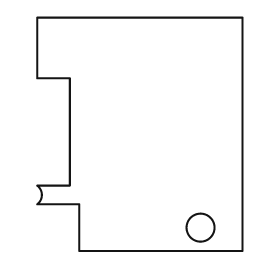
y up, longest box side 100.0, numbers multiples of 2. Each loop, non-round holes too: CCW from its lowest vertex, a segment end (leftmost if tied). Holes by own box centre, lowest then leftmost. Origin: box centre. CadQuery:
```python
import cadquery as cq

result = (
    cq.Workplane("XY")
    .moveTo(-26.0, -50.0)
    .lineTo(44.0, -50.0)
    .lineTo(44.0, 50.0)
    .lineTo(-44.0, 50.0)
    .lineTo(-44.0, 24.0)
    .lineTo(-30.0, 24.0)
    .lineTo(-30.0, -22.0)
    .lineTo(-44.0, -22.0)
    .threePointArc((-42.0, -26.0), (-44.0, -30.0))
    .lineTo(-26.0, -30.0)
    .close()
    .moveTo(26.0, -40.0)
    .circle(6.0)
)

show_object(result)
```